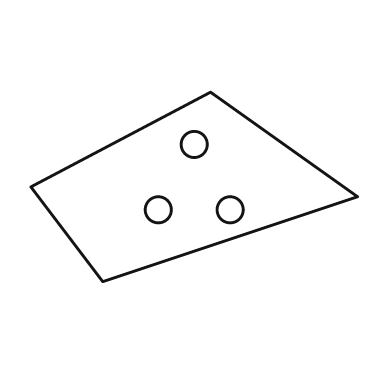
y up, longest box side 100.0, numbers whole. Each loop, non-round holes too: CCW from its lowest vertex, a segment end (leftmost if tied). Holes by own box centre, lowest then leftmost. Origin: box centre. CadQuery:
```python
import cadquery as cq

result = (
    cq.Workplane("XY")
    .moveTo(-28.0, -29.0)
    .lineTo(50.0, -3.0)
    .lineTo(5.0, 29.0)
    .lineTo(-50.0, 0.0)
    .close()
    .moveTo(-11.0, -7.0)
    .circle(4.0)
    .moveTo(11.0, -7.0)
    .circle(4.0)
    .moveTo(0.0, 13.0)
    .circle(4.0)
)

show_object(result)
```